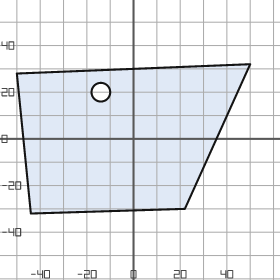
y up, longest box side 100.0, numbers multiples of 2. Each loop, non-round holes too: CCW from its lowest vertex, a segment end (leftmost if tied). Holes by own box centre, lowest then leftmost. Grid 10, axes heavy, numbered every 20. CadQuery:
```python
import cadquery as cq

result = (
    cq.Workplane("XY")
    .moveTo(-44.0, -32.0)
    .lineTo(22.0, -30.0)
    .lineTo(50.0, 32.0)
    .lineTo(-50.0, 28.0)
    .close()
    .moveTo(-14.0, 20.0)
    .circle(4.0)
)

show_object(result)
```